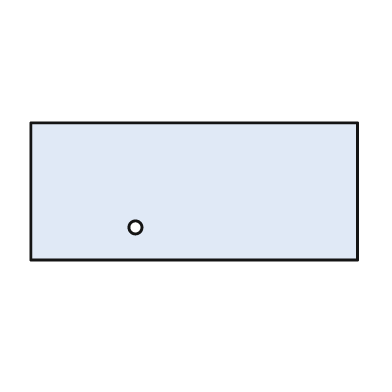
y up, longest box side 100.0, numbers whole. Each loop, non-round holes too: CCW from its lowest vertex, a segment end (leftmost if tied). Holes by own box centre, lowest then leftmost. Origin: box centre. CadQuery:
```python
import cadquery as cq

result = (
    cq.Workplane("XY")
    .moveTo(-50.0, -21.0)
    .lineTo(50.0, -21.0)
    .lineTo(50.0, 21.0)
    .lineTo(-50.0, 21.0)
    .close()
    .moveTo(-18.0, -11.0)
    .circle(2.0)
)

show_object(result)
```